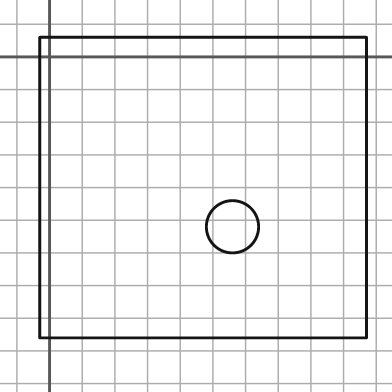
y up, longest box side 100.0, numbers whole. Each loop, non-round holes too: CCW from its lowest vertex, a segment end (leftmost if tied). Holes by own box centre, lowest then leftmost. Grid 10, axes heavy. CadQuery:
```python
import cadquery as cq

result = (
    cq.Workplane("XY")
    .moveTo(-3.0, -86.0)
    .lineTo(97.0, -86.0)
    .lineTo(97.0, 6.0)
    .lineTo(-3.0, 6.0)
    .close()
    .moveTo(56.0, -52.0)
    .circle(8.0)
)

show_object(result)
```